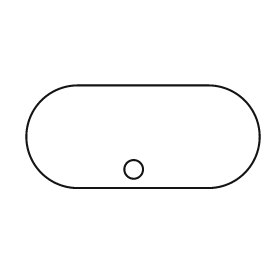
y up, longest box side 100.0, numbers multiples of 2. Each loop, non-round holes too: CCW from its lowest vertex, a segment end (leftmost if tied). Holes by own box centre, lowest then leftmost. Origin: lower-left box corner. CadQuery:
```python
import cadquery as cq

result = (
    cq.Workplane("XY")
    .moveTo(22.0, 0.0)
    .lineTo(78.0, 0.0)
    .threePointArc((100.0, 22.0), (78.0, 44.0))
    .lineTo(22.0, 44.0)
    .threePointArc((0.0, 22.0), (22.0, 0.0))
    .close()
    .moveTo(46.0, 8.0)
    .circle(4.0)
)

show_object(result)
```